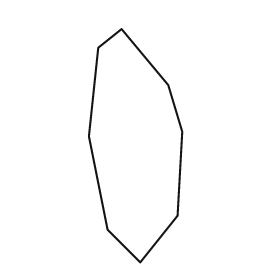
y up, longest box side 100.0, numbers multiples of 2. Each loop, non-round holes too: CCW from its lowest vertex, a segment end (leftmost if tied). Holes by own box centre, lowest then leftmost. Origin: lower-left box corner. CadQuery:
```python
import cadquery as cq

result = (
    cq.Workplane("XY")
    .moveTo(22.0, 0.0)
    .lineTo(38.0, 20.0)
    .lineTo(40.0, 56.0)
    .lineTo(34.0, 76.0)
    .lineTo(14.0, 100.0)
    .lineTo(4.0, 92.0)
    .lineTo(0.0, 54.0)
    .lineTo(8.0, 14.0)
    .close()
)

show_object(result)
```